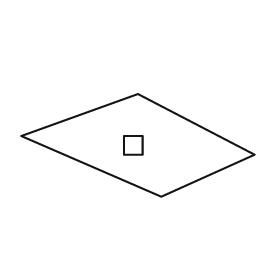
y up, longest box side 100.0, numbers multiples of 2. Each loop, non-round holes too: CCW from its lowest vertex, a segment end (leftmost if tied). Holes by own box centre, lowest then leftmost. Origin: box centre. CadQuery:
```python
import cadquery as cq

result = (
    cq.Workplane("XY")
    .moveTo(10.0, -22.0)
    .lineTo(50.0, -4.0)
    .lineTo(0.0, 22.0)
    .lineTo(-50.0, 4.0)
    .close()
    .moveTo(-6.0, -4.0)
    .lineTo(2.0, -4.0)
    .lineTo(2.0, 4.0)
    .lineTo(-6.0, 4.0)
    .close()
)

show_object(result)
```